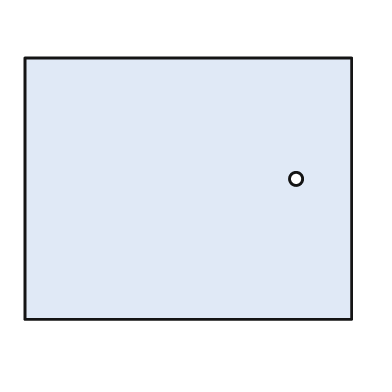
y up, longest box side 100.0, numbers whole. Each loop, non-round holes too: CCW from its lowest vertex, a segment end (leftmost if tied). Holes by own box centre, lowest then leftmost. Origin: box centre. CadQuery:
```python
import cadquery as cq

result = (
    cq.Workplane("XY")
    .moveTo(-50.0, -40.0)
    .lineTo(50.0, -40.0)
    .lineTo(50.0, 40.0)
    .lineTo(-50.0, 40.0)
    .close()
    .moveTo(33.0, 3.0)
    .circle(2.0)
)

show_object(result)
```